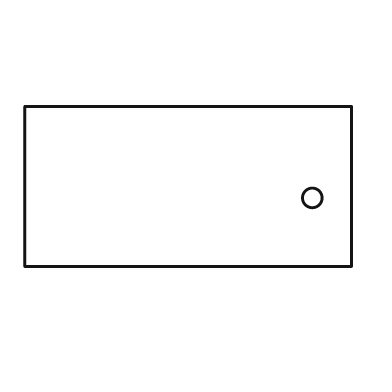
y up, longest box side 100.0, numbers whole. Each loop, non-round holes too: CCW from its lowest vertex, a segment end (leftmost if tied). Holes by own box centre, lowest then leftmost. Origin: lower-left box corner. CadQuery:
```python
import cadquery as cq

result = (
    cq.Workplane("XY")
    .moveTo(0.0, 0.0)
    .lineTo(100.0, 0.0)
    .lineTo(100.0, 49.0)
    .lineTo(0.0, 49.0)
    .close()
    .moveTo(88.0, 21.0)
    .circle(3.0)
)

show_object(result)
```